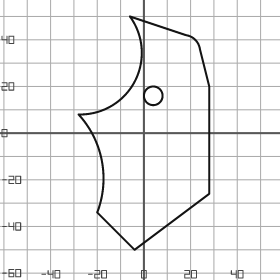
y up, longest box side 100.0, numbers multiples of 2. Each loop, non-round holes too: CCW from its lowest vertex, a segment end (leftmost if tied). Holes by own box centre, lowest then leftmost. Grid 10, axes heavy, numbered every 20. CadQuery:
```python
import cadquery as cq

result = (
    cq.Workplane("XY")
    .moveTo(-4.0, -50.0)
    .lineTo(28.0, -26.0)
    .lineTo(28.0, 20.0)
    .lineTo(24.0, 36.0)
    .threePointArc((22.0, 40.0), (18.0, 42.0))
    .lineTo(-6.0, 50.0)
    .threePointArc((-4.0, 22.0), (-28.0, 8.0))
    .threePointArc((-18.0, -12.0), (-20.0, -34.0))
    .close()
    .moveTo(4.0, 16.0)
    .circle(4.0)
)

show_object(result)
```